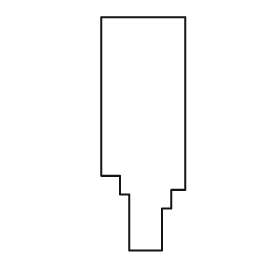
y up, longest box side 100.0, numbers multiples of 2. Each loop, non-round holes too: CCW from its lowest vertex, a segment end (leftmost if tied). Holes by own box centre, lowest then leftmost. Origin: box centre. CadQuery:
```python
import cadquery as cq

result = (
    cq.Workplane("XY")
    .moveTo(-6.0, -50.0)
    .lineTo(8.0, -50.0)
    .lineTo(8.0, -32.0)
    .lineTo(12.0, -32.0)
    .lineTo(12.0, -24.0)
    .lineTo(18.0, -24.0)
    .lineTo(18.0, 50.0)
    .lineTo(-18.0, 50.0)
    .lineTo(-18.0, -18.0)
    .lineTo(-10.0, -18.0)
    .lineTo(-10.0, -26.0)
    .lineTo(-6.0, -26.0)
    .close()
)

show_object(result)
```